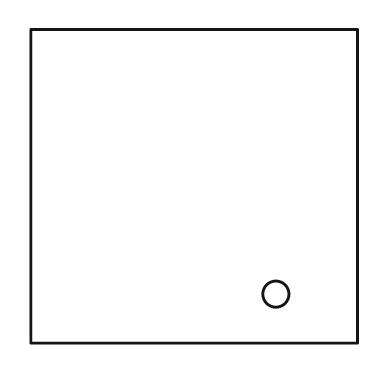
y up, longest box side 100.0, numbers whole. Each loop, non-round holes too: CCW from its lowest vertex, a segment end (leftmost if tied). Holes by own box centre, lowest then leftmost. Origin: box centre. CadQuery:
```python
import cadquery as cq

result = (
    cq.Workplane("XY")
    .moveTo(-50.0, -48.0)
    .lineTo(50.0, -48.0)
    .lineTo(50.0, 48.0)
    .lineTo(-50.0, 48.0)
    .close()
    .moveTo(25.0, -33.0)
    .circle(4.0)
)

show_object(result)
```